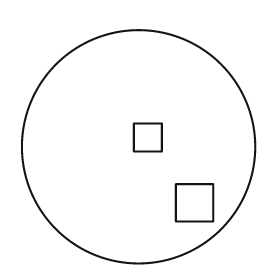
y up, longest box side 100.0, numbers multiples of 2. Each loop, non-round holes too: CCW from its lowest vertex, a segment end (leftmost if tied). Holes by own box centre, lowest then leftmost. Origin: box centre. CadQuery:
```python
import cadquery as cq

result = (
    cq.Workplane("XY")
    .moveTo(0.0, 0.0)
    .circle(50.0)
    .moveTo(16.0, -32.0)
    .lineTo(32.0, -32.0)
    .lineTo(32.0, -16.0)
    .lineTo(16.0, -16.0)
    .close()
    .moveTo(-2.0, -2.0)
    .lineTo(10.0, -2.0)
    .lineTo(10.0, 10.0)
    .lineTo(-2.0, 10.0)
    .close()
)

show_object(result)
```